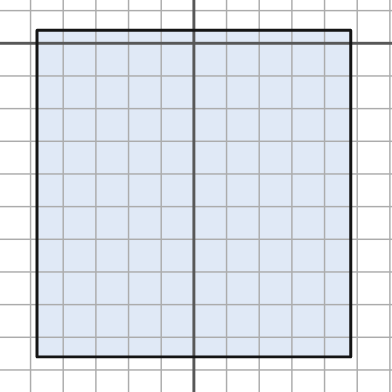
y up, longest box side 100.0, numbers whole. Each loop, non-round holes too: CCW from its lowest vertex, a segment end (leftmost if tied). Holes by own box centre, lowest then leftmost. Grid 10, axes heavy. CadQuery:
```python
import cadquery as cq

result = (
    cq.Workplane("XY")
    .moveTo(-48.0, -96.0)
    .lineTo(48.0, -96.0)
    .lineTo(48.0, 4.0)
    .lineTo(-48.0, 4.0)
    .close()
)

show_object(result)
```